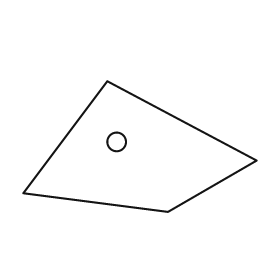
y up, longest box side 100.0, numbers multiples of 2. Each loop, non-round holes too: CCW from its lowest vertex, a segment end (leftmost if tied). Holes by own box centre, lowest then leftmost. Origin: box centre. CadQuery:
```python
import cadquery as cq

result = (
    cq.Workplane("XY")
    .moveTo(12.0, -28.0)
    .lineTo(50.0, -6.0)
    .lineTo(-14.0, 28.0)
    .lineTo(-50.0, -20.0)
    .close()
    .moveTo(-10.0, 2.0)
    .circle(4.0)
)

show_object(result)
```